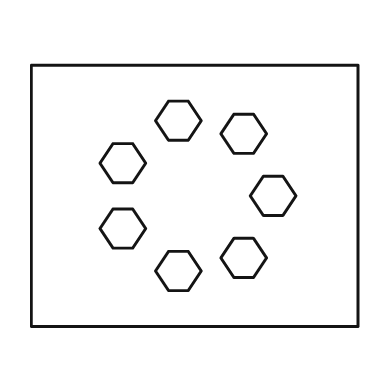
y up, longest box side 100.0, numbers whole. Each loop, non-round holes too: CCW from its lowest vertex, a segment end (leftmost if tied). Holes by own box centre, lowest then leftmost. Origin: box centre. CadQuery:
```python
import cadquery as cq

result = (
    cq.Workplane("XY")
    .moveTo(-50.0, -40.0)
    .lineTo(50.0, -40.0)
    .lineTo(50.0, 40.0)
    .lineTo(-50.0, 40.0)
    .close()
    .moveTo(-8.0, -29.0)
    .lineTo(-2.0, -29.0)
    .lineTo(2.0, -23.0)
    .lineTo(-2.0, -17.0)
    .lineTo(-8.0, -17.0)
    .lineTo(-12.0, -23.0)
    .close()
    .moveTo(12.0, -25.0)
    .lineTo(18.0, -25.0)
    .lineTo(22.0, -19.0)
    .lineTo(18.0, -13.0)
    .lineTo(12.0, -13.0)
    .lineTo(8.0, -19.0)
    .close()
    .moveTo(-25.0, -16.0)
    .lineTo(-19.0, -16.0)
    .lineTo(-15.0, -10.0)
    .lineTo(-19.0, -4.0)
    .lineTo(-25.0, -4.0)
    .lineTo(-29.0, -10.0)
    .close()
    .moveTo(21.0, -6.0)
    .lineTo(27.0, -6.0)
    .lineTo(31.0, 0.0)
    .lineTo(27.0, 6.0)
    .lineTo(21.0, 6.0)
    .lineTo(17.0, 0.0)
    .close()
    .moveTo(-25.0, 4.0)
    .lineTo(-19.0, 4.0)
    .lineTo(-15.0, 10.0)
    .lineTo(-19.0, 16.0)
    .lineTo(-25.0, 16.0)
    .lineTo(-29.0, 10.0)
    .close()
    .moveTo(12.0, 13.0)
    .lineTo(18.0, 13.0)
    .lineTo(22.0, 19.0)
    .lineTo(18.0, 25.0)
    .lineTo(12.0, 25.0)
    .lineTo(8.0, 19.0)
    .close()
    .moveTo(-8.0, 17.0)
    .lineTo(-2.0, 17.0)
    .lineTo(2.0, 23.0)
    .lineTo(-2.0, 29.0)
    .lineTo(-8.0, 29.0)
    .lineTo(-12.0, 23.0)
    .close()
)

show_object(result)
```